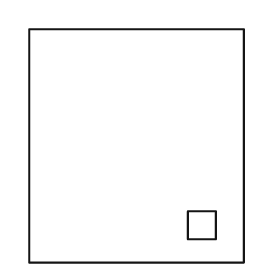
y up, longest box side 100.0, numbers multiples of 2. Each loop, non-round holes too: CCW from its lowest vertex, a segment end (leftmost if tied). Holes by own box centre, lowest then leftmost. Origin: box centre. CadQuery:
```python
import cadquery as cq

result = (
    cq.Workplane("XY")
    .moveTo(-46.0, -50.0)
    .lineTo(46.0, -50.0)
    .lineTo(46.0, 50.0)
    .lineTo(-46.0, 50.0)
    .close()
    .moveTo(22.0, -40.0)
    .lineTo(34.0, -40.0)
    .lineTo(34.0, -28.0)
    .lineTo(22.0, -28.0)
    .close()
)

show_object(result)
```